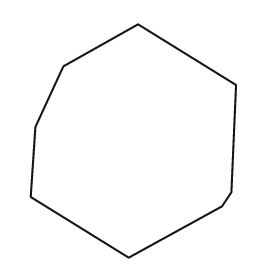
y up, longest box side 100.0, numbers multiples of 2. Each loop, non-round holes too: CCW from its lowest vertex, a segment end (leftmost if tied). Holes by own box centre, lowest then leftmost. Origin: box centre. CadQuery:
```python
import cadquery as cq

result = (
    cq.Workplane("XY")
    .moveTo(-2.0, -50.0)
    .lineTo(38.0, -28.0)
    .lineTo(42.0, -22.0)
    .lineTo(44.0, 24.0)
    .lineTo(2.0, 50.0)
    .lineTo(-30.0, 32.0)
    .lineTo(-42.0, 6.0)
    .lineTo(-44.0, -24.0)
    .close()
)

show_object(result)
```